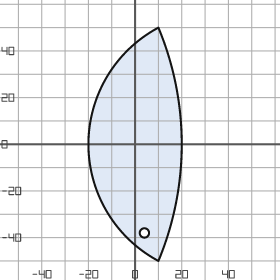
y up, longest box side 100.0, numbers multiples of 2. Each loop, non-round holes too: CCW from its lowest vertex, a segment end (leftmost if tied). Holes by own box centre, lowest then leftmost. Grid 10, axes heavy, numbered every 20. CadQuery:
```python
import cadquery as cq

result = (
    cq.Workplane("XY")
    .moveTo(10.0, -50.0)
    .threePointArc((20.0, 0.0), (10.0, 50.0))
    .threePointArc((-20.0, 0.0), (10.0, -50.0))
    .close()
    .moveTo(4.0, -38.0)
    .circle(2.0)
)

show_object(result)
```